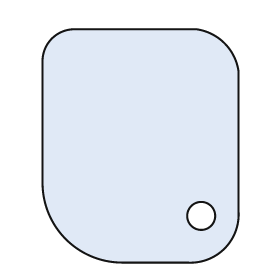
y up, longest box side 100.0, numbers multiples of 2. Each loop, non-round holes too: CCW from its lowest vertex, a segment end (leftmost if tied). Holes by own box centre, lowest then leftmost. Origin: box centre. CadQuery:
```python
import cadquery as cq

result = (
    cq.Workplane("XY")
    .moveTo(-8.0, -50.0)
    .lineTo(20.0, -50.0)
    .threePointArc((36.0, -44.0), (42.0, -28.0))
    .lineTo(42.0, 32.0)
    .threePointArc((36.0, 44.0), (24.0, 50.0))
    .lineTo(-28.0, 50.0)
    .threePointArc((-38.0, 46.0), (-42.0, 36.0))
    .lineTo(-42.0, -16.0)
    .threePointArc((-32.0, -40.0), (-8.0, -50.0))
    .close()
    .moveTo(26.0, -30.0)
    .circle(6.0)
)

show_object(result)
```